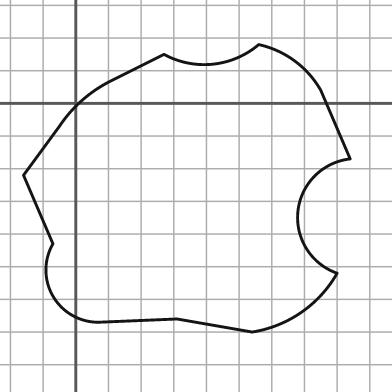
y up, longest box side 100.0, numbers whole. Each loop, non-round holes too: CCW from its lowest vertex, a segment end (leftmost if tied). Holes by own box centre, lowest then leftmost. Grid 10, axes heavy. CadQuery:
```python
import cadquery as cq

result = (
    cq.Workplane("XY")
    .moveTo(54.0, -70.0)
    .threePointArc((69.0, -64.0), (80.0, -52.0))
    .threePointArc((68.0, -33.0), (84.0, -17.0))
    .lineTo(75.0, 4.0)
    .threePointArc((67.0, 13.0), (56.0, 18.0))
    .threePointArc((42.0, 12.0), (27.0, 15.0))
    .lineTo(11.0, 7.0)
    .threePointArc((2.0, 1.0), (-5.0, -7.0))
    .lineTo(-16.0, -22.0)
    .lineTo(-7.0, -43.0)
    .threePointArc((-7.0, -59.0), (7.0, -67.0))
    .lineTo(31.0, -66.0)
    .close()
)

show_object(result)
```